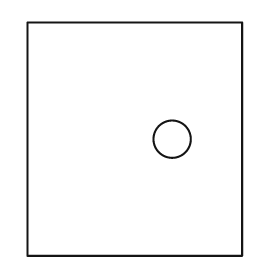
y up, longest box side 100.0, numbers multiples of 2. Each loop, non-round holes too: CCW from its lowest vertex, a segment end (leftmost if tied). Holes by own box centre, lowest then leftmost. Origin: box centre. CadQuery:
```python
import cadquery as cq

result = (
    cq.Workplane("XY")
    .moveTo(-46.0, -50.0)
    .lineTo(46.0, -50.0)
    .lineTo(46.0, 50.0)
    .lineTo(-46.0, 50.0)
    .close()
    .moveTo(16.0, 0.0)
    .circle(8.0)
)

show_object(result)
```